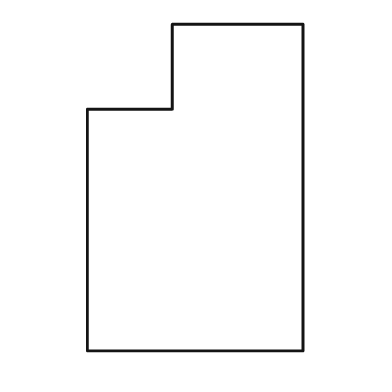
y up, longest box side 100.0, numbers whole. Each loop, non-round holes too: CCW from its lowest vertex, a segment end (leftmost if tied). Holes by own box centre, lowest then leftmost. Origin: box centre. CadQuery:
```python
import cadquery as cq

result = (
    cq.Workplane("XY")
    .moveTo(-33.0, -50.0)
    .lineTo(33.0, -50.0)
    .lineTo(33.0, 50.0)
    .lineTo(-7.0, 50.0)
    .lineTo(-7.0, 24.0)
    .lineTo(-33.0, 24.0)
    .close()
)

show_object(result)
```